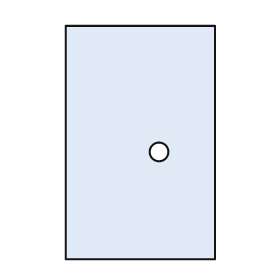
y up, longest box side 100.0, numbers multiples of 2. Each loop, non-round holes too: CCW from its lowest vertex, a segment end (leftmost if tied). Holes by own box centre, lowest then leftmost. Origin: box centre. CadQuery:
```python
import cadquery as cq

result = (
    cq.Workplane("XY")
    .moveTo(-32.0, -50.0)
    .lineTo(32.0, -50.0)
    .lineTo(32.0, 50.0)
    .lineTo(-32.0, 50.0)
    .close()
    .moveTo(8.0, -4.0)
    .circle(4.0)
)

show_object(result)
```